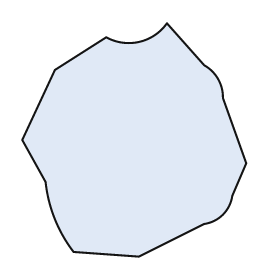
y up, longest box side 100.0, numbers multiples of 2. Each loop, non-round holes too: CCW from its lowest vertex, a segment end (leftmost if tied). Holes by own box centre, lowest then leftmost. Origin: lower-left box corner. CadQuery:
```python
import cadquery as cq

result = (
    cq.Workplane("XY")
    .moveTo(50.0, 0.0)
    .lineTo(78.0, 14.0)
    .threePointArc((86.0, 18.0), (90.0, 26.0))
    .lineTo(96.0, 40.0)
    .lineTo(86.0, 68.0)
    .threePointArc((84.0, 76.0), (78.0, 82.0))
    .lineTo(62.0, 100.0)
    .threePointArc((50.0, 92.0), (36.0, 94.0))
    .lineTo(14.0, 80.0)
    .lineTo(0.0, 50.0)
    .lineTo(10.0, 32.0)
    .threePointArc((14.0, 16.0), (22.0, 2.0))
    .close()
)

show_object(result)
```